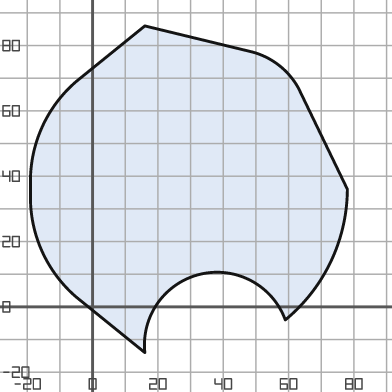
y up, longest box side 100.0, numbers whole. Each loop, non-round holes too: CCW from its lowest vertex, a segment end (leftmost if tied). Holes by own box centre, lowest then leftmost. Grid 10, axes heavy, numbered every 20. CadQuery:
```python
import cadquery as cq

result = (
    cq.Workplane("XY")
    .moveTo(16.0, -14.0)
    .threePointArc((33.0, 10.0), (59.0, -4.0))
    .threePointArc((73.0, 14.0), (78.0, 36.0))
    .lineTo(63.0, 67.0)
    .threePointArc((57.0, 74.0), (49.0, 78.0))
    .lineTo(16.0, 86.0)
    .lineTo(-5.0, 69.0)
    .threePointArc((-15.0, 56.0), (-19.0, 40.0))
    .lineTo(-19.0, 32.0)
    .threePointArc((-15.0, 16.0), (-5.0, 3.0))
    .close()
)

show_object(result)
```